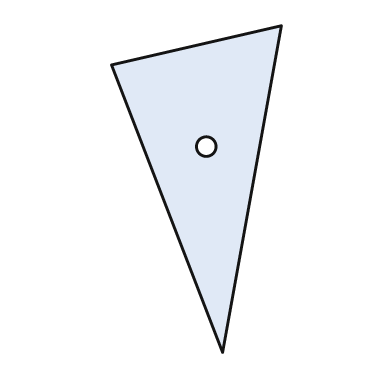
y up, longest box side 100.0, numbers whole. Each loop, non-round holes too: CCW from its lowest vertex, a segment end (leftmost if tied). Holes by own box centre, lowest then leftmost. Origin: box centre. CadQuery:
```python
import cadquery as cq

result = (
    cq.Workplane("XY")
    .moveTo(8.0, -50.0)
    .lineTo(26.0, 50.0)
    .lineTo(-26.0, 38.0)
    .close()
    .moveTo(3.0, 13.0)
    .circle(3.0)
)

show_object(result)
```